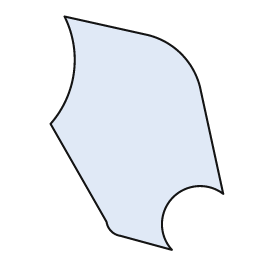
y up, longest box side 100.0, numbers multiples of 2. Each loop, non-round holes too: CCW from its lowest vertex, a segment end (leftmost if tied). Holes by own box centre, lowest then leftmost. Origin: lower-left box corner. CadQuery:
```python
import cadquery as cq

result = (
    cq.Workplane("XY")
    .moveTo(52.0, 0.0)
    .threePointArc((52.0, 22.0), (74.0, 24.0))
    .lineTo(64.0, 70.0)
    .threePointArc((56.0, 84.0), (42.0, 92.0))
    .lineTo(6.0, 100.0)
    .threePointArc((10.0, 76.0), (0.0, 54.0))
    .lineTo(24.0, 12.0)
    .threePointArc((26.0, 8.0), (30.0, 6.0))
    .close()
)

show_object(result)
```